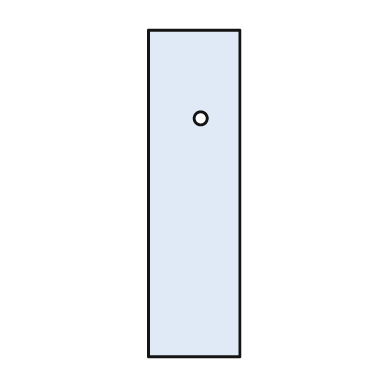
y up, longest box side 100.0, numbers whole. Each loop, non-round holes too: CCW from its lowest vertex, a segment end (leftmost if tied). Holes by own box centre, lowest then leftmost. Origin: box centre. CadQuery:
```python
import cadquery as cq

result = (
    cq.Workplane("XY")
    .moveTo(-14.0, -50.0)
    .lineTo(14.0, -50.0)
    .lineTo(14.0, 50.0)
    .lineTo(-14.0, 50.0)
    .close()
    .moveTo(2.0, 23.0)
    .circle(2.0)
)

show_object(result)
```